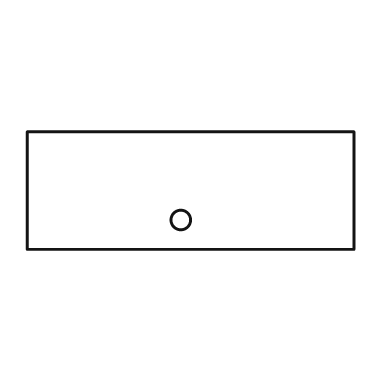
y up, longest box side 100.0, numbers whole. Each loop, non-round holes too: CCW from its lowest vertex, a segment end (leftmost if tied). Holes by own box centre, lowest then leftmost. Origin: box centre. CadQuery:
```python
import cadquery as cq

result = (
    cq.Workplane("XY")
    .moveTo(-50.0, -18.0)
    .lineTo(50.0, -18.0)
    .lineTo(50.0, 18.0)
    .lineTo(-50.0, 18.0)
    .close()
    .moveTo(-3.0, -9.0)
    .circle(3.0)
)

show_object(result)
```